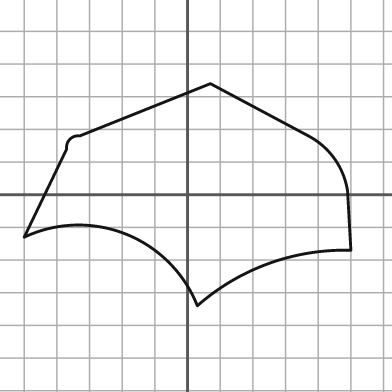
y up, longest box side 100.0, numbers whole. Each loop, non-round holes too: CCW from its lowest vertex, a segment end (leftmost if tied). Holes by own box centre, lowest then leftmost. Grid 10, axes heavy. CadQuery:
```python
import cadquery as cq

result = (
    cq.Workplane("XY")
    .moveTo(3.0, -34.0)
    .threePointArc((25.0, -21.0), (50.0, -17.0))
    .lineTo(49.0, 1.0)
    .threePointArc((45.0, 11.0), (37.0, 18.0))
    .lineTo(7.0, 34.0)
    .lineTo(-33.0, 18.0)
    .threePointArc((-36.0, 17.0), (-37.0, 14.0))
    .lineTo(-50.0, -13.0)
    .threePointArc((-19.0, -12.0), (3.0, -34.0))
    .close()
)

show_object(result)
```